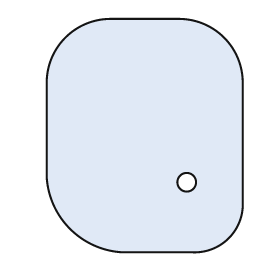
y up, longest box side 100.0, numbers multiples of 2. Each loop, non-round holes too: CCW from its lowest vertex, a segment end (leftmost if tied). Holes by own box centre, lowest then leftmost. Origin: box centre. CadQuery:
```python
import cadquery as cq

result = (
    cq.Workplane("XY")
    .moveTo(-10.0, -50.0)
    .lineTo(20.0, -50.0)
    .threePointArc((36.0, -44.0), (42.0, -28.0))
    .lineTo(42.0, 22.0)
    .threePointArc((34.0, 42.0), (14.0, 50.0))
    .lineTo(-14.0, 50.0)
    .threePointArc((-34.0, 42.0), (-42.0, 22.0))
    .lineTo(-42.0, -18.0)
    .threePointArc((-32.0, -40.0), (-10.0, -50.0))
    .close()
    .moveTo(18.0, -20.0)
    .circle(4.0)
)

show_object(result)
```